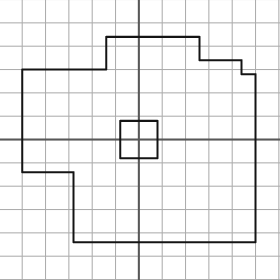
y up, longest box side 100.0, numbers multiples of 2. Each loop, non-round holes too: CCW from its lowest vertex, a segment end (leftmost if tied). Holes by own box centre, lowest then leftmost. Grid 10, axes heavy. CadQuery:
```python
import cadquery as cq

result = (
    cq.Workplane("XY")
    .moveTo(-28.0, -44.0)
    .lineTo(50.0, -44.0)
    .lineTo(50.0, 28.0)
    .lineTo(44.0, 28.0)
    .lineTo(44.0, 34.0)
    .lineTo(26.0, 34.0)
    .lineTo(26.0, 44.0)
    .lineTo(-14.0, 44.0)
    .lineTo(-14.0, 30.0)
    .lineTo(-50.0, 30.0)
    .lineTo(-50.0, -14.0)
    .lineTo(-28.0, -14.0)
    .close()
    .moveTo(-8.0, -8.0)
    .lineTo(8.0, -8.0)
    .lineTo(8.0, 8.0)
    .lineTo(-8.0, 8.0)
    .close()
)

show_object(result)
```